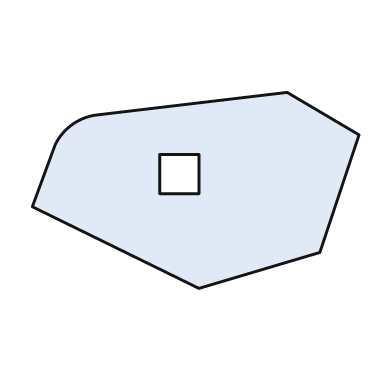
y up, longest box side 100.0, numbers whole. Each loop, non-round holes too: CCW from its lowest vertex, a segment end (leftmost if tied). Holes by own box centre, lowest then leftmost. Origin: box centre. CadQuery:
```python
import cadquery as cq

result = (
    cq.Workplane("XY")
    .moveTo(1.0, -30.0)
    .lineTo(38.0, -19.0)
    .lineTo(50.0, 17.0)
    .lineTo(28.0, 30.0)
    .lineTo(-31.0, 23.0)
    .threePointArc((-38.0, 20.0), (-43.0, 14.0))
    .lineTo(-50.0, -5.0)
    .close()
    .moveTo(-11.0, -1.0)
    .lineTo(1.0, -1.0)
    .lineTo(1.0, 11.0)
    .lineTo(-11.0, 11.0)
    .close()
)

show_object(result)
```